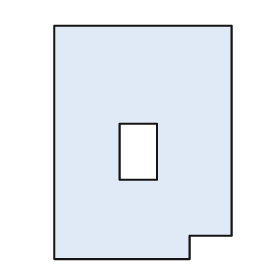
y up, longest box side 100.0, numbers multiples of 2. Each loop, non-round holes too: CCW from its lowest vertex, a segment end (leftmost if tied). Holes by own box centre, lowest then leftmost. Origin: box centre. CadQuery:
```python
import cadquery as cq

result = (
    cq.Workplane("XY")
    .moveTo(-38.0, -50.0)
    .lineTo(20.0, -50.0)
    .lineTo(20.0, -40.0)
    .lineTo(38.0, -40.0)
    .lineTo(38.0, 50.0)
    .lineTo(-38.0, 50.0)
    .close()
    .moveTo(-10.0, -16.0)
    .lineTo(6.0, -16.0)
    .lineTo(6.0, 8.0)
    .lineTo(-10.0, 8.0)
    .close()
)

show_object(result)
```